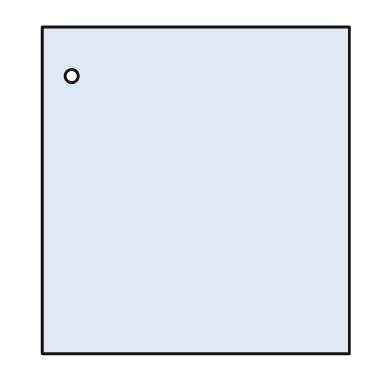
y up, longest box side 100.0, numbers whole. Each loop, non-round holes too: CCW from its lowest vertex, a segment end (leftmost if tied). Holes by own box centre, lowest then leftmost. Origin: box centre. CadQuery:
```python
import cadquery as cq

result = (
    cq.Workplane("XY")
    .moveTo(-47.0, -50.0)
    .lineTo(47.0, -50.0)
    .lineTo(47.0, 50.0)
    .lineTo(-47.0, 50.0)
    .close()
    .moveTo(-38.0, 35.0)
    .circle(2.0)
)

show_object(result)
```